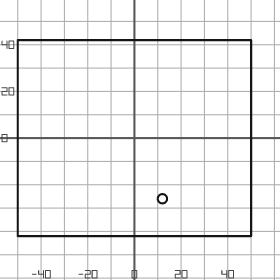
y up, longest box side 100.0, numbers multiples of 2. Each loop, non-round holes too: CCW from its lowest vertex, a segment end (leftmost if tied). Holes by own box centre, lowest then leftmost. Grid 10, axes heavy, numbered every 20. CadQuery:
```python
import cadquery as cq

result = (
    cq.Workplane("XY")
    .moveTo(-50.0, -42.0)
    .lineTo(50.0, -42.0)
    .lineTo(50.0, 42.0)
    .lineTo(-50.0, 42.0)
    .close()
    .moveTo(12.0, -26.0)
    .circle(2.0)
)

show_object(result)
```